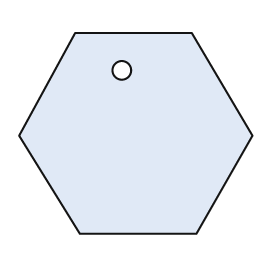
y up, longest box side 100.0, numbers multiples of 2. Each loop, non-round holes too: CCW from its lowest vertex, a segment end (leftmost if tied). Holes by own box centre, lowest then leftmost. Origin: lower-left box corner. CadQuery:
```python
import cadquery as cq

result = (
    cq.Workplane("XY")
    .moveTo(26.0, 0.0)
    .lineTo(76.0, 0.0)
    .lineTo(100.0, 42.0)
    .lineTo(74.0, 86.0)
    .lineTo(24.0, 86.0)
    .lineTo(0.0, 42.0)
    .close()
    .moveTo(44.0, 70.0)
    .circle(4.0)
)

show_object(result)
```